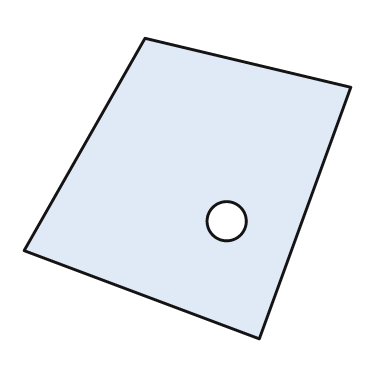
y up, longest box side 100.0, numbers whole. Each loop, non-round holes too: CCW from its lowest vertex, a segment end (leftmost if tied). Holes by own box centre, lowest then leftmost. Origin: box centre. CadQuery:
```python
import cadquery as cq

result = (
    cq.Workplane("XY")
    .moveTo(22.0, -46.0)
    .lineTo(50.0, 31.0)
    .lineTo(-13.0, 46.0)
    .lineTo(-50.0, -19.0)
    .close()
    .moveTo(12.0, -10.0)
    .circle(6.0)
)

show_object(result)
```